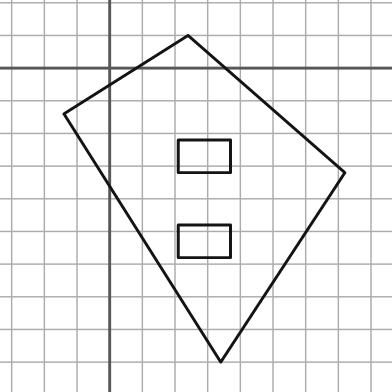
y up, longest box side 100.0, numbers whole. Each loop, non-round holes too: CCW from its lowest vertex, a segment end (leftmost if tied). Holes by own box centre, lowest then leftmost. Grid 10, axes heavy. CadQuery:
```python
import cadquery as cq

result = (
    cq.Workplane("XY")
    .moveTo(34.0, -90.0)
    .lineTo(72.0, -32.0)
    .lineTo(24.0, 10.0)
    .lineTo(-14.0, -14.0)
    .close()
    .moveTo(21.0, -58.0)
    .lineTo(37.0, -58.0)
    .lineTo(37.0, -48.0)
    .lineTo(21.0, -48.0)
    .close()
    .moveTo(21.0, -32.0)
    .lineTo(37.0, -32.0)
    .lineTo(37.0, -22.0)
    .lineTo(21.0, -22.0)
    .close()
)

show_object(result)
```